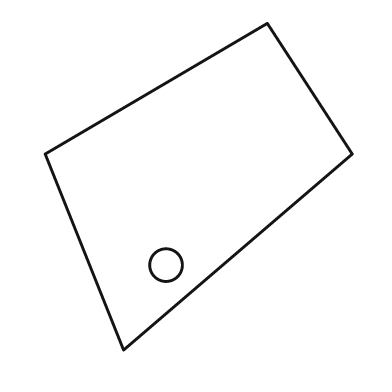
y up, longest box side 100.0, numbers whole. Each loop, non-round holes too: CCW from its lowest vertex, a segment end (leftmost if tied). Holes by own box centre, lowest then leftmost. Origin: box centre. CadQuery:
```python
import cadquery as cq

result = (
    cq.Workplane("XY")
    .moveTo(-23.0, -50.0)
    .lineTo(47.0, 10.0)
    .lineTo(21.0, 50.0)
    .lineTo(-47.0, 10.0)
    .close()
    .moveTo(-10.0, -24.0)
    .circle(5.0)
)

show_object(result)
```